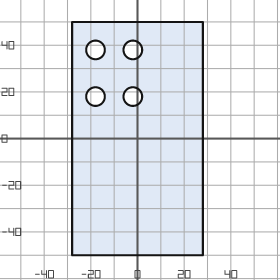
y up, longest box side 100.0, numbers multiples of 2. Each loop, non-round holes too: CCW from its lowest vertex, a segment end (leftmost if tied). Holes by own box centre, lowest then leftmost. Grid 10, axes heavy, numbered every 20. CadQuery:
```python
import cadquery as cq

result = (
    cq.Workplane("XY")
    .moveTo(-28.0, -50.0)
    .lineTo(28.0, -50.0)
    .lineTo(28.0, 50.0)
    .lineTo(-28.0, 50.0)
    .close()
    .moveTo(-18.0, 18.0)
    .circle(4.0)
    .moveTo(-2.0, 18.0)
    .circle(4.0)
    .moveTo(-18.0, 38.0)
    .circle(4.0)
    .moveTo(-2.0, 38.0)
    .circle(4.0)
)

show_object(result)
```